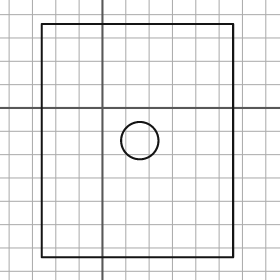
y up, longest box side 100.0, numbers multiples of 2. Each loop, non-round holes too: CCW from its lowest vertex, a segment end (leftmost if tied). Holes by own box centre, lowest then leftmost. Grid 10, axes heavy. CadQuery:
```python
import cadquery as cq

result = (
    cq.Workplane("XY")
    .moveTo(-26.0, -64.0)
    .lineTo(56.0, -64.0)
    .lineTo(56.0, 36.0)
    .lineTo(-26.0, 36.0)
    .close()
    .moveTo(16.0, -14.0)
    .circle(8.0)
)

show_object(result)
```